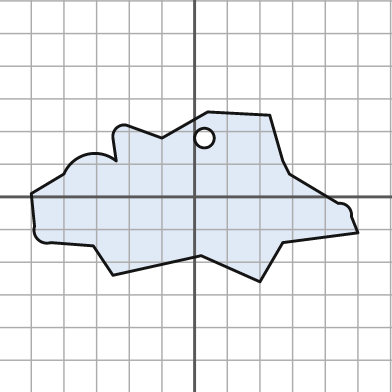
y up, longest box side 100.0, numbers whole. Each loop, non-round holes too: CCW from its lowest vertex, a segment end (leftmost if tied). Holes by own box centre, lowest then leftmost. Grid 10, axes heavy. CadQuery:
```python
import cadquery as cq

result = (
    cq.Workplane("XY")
    .moveTo(20.0, -26.0)
    .lineTo(27.0, -14.0)
    .lineTo(50.0, -11.0)
    .lineTo(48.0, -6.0)
    .threePointArc((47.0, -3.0), (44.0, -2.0))
    .lineTo(29.0, 7.0)
    .lineTo(27.0, 11.0)
    .lineTo(23.0, 25.0)
    .lineTo(4.0, 26.0)
    .lineTo(-10.0, 18.0)
    .lineTo(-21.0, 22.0)
    .threePointArc((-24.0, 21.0), (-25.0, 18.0))
    .lineTo(-24.0, 11.0)
    .threePointArc((-33.0, 13.0), (-40.0, 7.0))
    .lineTo(-50.0, 1.0)
    .lineTo(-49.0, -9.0)
    .threePointArc((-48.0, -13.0), (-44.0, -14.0))
    .lineTo(-31.0, -15.0)
    .lineTo(-25.0, -24.0)
    .lineTo(2.0, -18.0)
    .close()
    .moveTo(3.0, 18.0)
    .circle(3.0)
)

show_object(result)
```